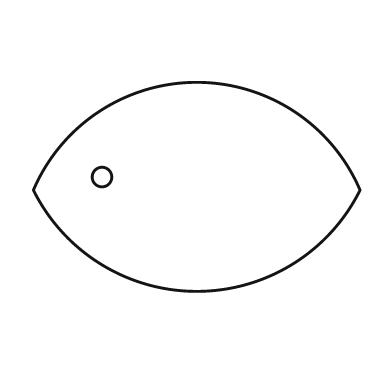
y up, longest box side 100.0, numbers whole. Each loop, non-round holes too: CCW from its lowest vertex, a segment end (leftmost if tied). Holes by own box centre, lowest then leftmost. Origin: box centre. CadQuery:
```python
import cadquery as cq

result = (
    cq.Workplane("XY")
    .moveTo(-50.0, -1.0)
    .threePointArc((0.0, -32.0), (50.0, -1.0))
    .threePointArc((0.0, 32.0), (-50.0, -1.0))
    .close()
    .moveTo(-29.0, 3.0)
    .circle(3.0)
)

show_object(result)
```